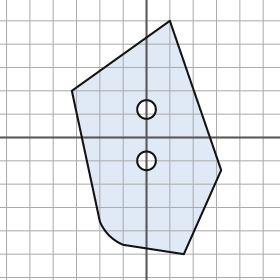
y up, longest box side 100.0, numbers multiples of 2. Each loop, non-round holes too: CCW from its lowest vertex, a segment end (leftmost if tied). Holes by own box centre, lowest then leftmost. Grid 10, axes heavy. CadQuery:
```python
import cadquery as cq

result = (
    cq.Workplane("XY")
    .moveTo(16.0, -50.0)
    .lineTo(32.0, -14.0)
    .lineTo(10.0, 50.0)
    .lineTo(-32.0, 20.0)
    .lineTo(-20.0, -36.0)
    .threePointArc((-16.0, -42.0), (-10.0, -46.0))
    .close()
    .moveTo(0.0, -10.0)
    .circle(4.0)
    .moveTo(0.0, 12.0)
    .circle(4.0)
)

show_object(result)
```